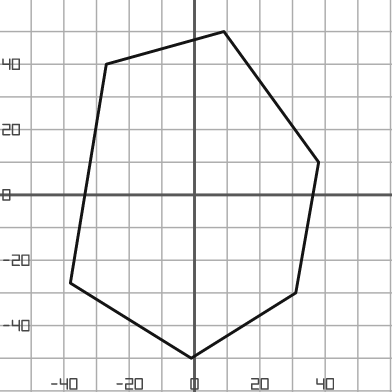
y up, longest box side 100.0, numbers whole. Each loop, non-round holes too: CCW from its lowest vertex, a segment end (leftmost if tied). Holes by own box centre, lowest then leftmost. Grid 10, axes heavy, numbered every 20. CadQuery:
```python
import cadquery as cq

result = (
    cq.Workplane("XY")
    .moveTo(-1.0, -50.0)
    .lineTo(31.0, -30.0)
    .lineTo(38.0, 10.0)
    .lineTo(9.0, 50.0)
    .lineTo(-27.0, 40.0)
    .lineTo(-38.0, -27.0)
    .close()
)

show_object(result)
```